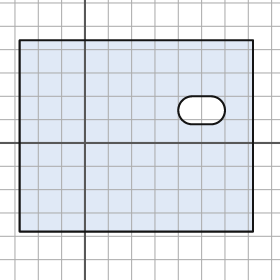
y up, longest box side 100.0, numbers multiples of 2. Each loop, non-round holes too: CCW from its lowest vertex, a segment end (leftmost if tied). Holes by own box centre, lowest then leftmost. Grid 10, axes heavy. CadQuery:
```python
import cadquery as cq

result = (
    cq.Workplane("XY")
    .moveTo(-28.0, -38.0)
    .lineTo(72.0, -38.0)
    .lineTo(72.0, 44.0)
    .lineTo(-28.0, 44.0)
    .close()
    .moveTo(46.0, 8.0)
    .lineTo(54.0, 8.0)
    .threePointArc((60.0, 14.0), (54.0, 20.0))
    .lineTo(46.0, 20.0)
    .threePointArc((40.0, 14.0), (46.0, 8.0))
    .close()
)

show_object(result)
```